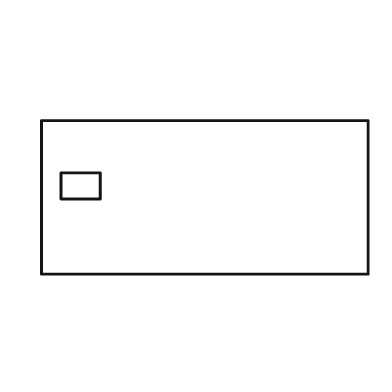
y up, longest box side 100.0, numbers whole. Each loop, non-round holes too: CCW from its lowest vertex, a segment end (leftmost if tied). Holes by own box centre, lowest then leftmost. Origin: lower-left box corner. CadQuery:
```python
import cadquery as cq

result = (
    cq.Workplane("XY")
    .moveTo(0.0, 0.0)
    .lineTo(100.0, 0.0)
    .lineTo(100.0, 47.0)
    .lineTo(0.0, 47.0)
    .close()
    .moveTo(6.0, 23.0)
    .lineTo(18.0, 23.0)
    .lineTo(18.0, 31.0)
    .lineTo(6.0, 31.0)
    .close()
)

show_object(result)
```